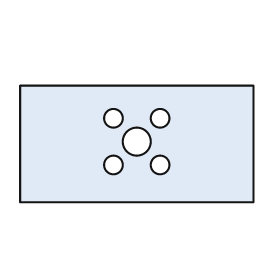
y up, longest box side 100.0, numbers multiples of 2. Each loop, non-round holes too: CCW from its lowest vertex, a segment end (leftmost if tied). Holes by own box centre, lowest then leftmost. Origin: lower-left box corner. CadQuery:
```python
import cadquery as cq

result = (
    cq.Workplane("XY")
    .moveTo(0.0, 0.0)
    .lineTo(100.0, 0.0)
    .lineTo(100.0, 50.0)
    .lineTo(0.0, 50.0)
    .close()
    .moveTo(40.0, 16.0)
    .circle(4.0)
    .moveTo(60.0, 16.0)
    .circle(4.0)
    .moveTo(50.0, 26.0)
    .circle(6.0)
    .moveTo(40.0, 36.0)
    .circle(4.0)
    .moveTo(60.0, 36.0)
    .circle(4.0)
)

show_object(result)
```